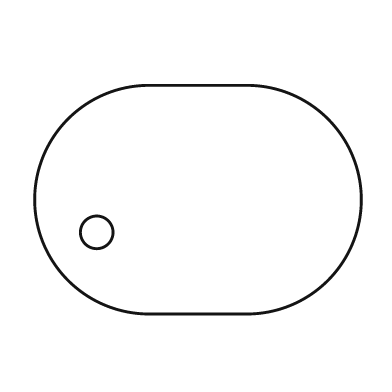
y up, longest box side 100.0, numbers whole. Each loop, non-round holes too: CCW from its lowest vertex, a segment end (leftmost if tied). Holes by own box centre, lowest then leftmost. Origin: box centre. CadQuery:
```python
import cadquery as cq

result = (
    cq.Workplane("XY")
    .moveTo(-15.0, -35.0)
    .lineTo(15.0, -35.0)
    .threePointArc((50.0, 0.0), (15.0, 35.0))
    .lineTo(-15.0, 35.0)
    .threePointArc((-50.0, 0.0), (-15.0, -35.0))
    .close()
    .moveTo(-31.0, -10.0)
    .circle(5.0)
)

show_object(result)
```